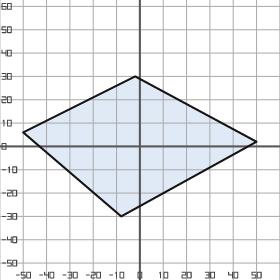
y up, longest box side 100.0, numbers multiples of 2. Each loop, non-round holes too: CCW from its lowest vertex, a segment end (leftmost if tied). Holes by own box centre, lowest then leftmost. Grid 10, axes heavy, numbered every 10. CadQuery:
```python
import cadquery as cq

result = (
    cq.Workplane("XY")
    .moveTo(-8.0, -30.0)
    .lineTo(50.0, 2.0)
    .lineTo(-2.0, 30.0)
    .lineTo(-50.0, 6.0)
    .close()
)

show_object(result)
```